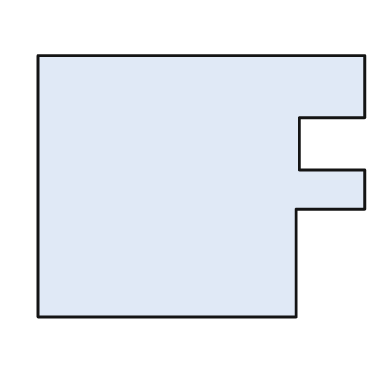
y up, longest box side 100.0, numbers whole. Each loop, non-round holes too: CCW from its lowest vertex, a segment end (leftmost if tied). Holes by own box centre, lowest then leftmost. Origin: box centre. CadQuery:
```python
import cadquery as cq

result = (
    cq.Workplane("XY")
    .moveTo(-50.0, -40.0)
    .lineTo(29.0, -40.0)
    .lineTo(29.0, -7.0)
    .lineTo(50.0, -7.0)
    .lineTo(50.0, 5.0)
    .lineTo(30.0, 5.0)
    .lineTo(30.0, 21.0)
    .lineTo(50.0, 21.0)
    .lineTo(50.0, 40.0)
    .lineTo(-50.0, 40.0)
    .close()
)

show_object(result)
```